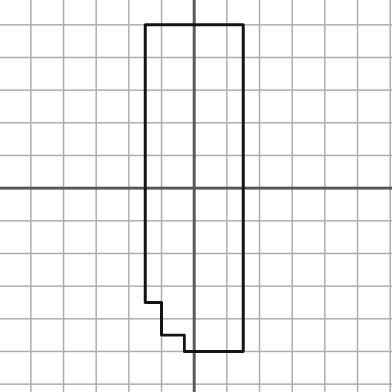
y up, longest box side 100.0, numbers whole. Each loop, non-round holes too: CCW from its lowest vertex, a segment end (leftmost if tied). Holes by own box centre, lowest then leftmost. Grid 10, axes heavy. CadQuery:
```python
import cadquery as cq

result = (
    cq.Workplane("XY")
    .moveTo(-3.0, -50.0)
    .lineTo(15.0, -50.0)
    .lineTo(15.0, 50.0)
    .lineTo(-15.0, 50.0)
    .lineTo(-15.0, -35.0)
    .lineTo(-10.0, -35.0)
    .lineTo(-10.0, -45.0)
    .lineTo(-3.0, -45.0)
    .close()
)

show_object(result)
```